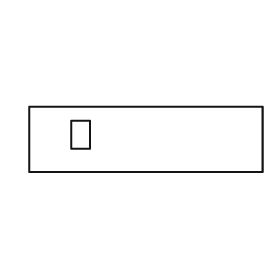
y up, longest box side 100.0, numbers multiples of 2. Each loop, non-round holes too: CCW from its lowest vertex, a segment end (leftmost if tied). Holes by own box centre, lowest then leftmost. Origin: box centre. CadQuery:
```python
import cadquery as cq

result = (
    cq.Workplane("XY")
    .moveTo(-50.0, -14.0)
    .lineTo(50.0, -14.0)
    .lineTo(50.0, 14.0)
    .lineTo(-50.0, 14.0)
    .close()
    .moveTo(-32.0, -4.0)
    .lineTo(-24.0, -4.0)
    .lineTo(-24.0, 8.0)
    .lineTo(-32.0, 8.0)
    .close()
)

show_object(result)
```